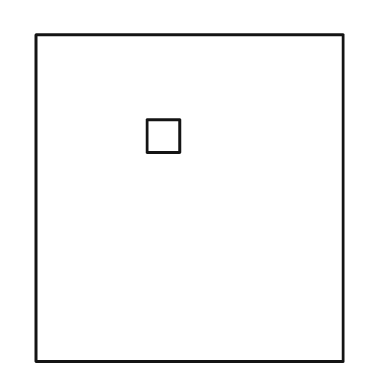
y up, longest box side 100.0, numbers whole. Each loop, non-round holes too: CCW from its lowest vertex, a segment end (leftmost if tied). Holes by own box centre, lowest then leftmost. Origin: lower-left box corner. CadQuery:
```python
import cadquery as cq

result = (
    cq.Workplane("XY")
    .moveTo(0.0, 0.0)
    .lineTo(94.0, 0.0)
    .lineTo(94.0, 100.0)
    .lineTo(0.0, 100.0)
    .close()
    .moveTo(34.0, 64.0)
    .lineTo(44.0, 64.0)
    .lineTo(44.0, 74.0)
    .lineTo(34.0, 74.0)
    .close()
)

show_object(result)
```